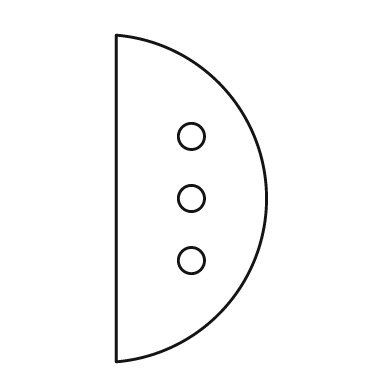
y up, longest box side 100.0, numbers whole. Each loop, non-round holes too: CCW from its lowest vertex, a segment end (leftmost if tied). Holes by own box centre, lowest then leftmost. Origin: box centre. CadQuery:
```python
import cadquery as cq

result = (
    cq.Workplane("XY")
    .moveTo(-23.0, -50.0)
    .threePointArc((23.0, 0.0), (-23.0, 50.0))
    .close()
    .moveTo(0.0, -19.0)
    .circle(4.0)
    .moveTo(0.0, 0.0)
    .circle(4.0)
    .moveTo(0.0, 19.0)
    .circle(4.0)
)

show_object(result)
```